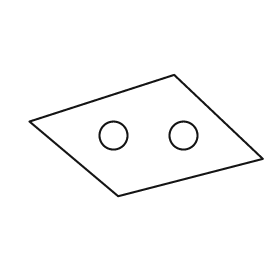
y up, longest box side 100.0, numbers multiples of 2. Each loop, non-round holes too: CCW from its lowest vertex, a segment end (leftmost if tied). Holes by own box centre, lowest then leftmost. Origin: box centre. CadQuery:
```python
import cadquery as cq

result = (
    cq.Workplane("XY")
    .moveTo(-12.0, -26.0)
    .lineTo(50.0, -10.0)
    .lineTo(12.0, 26.0)
    .lineTo(-50.0, 6.0)
    .close()
    .moveTo(-14.0, 0.0)
    .circle(6.0)
    .moveTo(16.0, 0.0)
    .circle(6.0)
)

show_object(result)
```